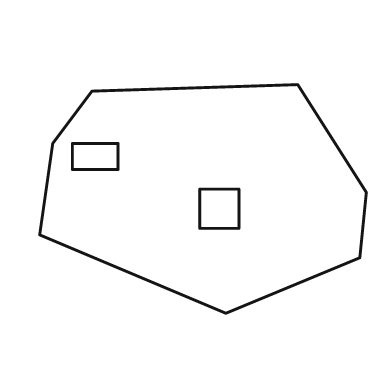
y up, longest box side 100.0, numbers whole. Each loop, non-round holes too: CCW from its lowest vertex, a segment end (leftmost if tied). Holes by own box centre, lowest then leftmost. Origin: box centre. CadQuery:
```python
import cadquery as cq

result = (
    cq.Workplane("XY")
    .moveTo(7.0, -35.0)
    .lineTo(48.0, -18.0)
    .lineTo(50.0, 2.0)
    .lineTo(29.0, 35.0)
    .lineTo(-34.0, 33.0)
    .lineTo(-46.0, 17.0)
    .lineTo(-50.0, -11.0)
    .close()
    .moveTo(-1.0, -9.0)
    .lineTo(11.0, -9.0)
    .lineTo(11.0, 3.0)
    .lineTo(-1.0, 3.0)
    .close()
    .moveTo(-40.0, 9.0)
    .lineTo(-26.0, 9.0)
    .lineTo(-26.0, 17.0)
    .lineTo(-40.0, 17.0)
    .close()
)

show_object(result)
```